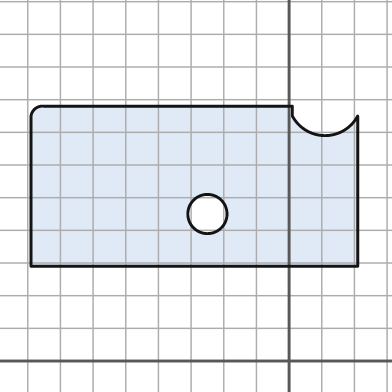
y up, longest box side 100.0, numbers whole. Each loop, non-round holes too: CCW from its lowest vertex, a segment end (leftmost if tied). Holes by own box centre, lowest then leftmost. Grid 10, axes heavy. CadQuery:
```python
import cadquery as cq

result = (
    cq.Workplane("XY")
    .moveTo(-79.0, 29.0)
    .lineTo(21.0, 29.0)
    .lineTo(21.0, 75.0)
    .threePointArc((11.0, 69.0), (1.0, 75.0))
    .lineTo(1.0, 78.0)
    .lineTo(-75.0, 78.0)
    .threePointArc((-78.0, 77.0), (-79.0, 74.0))
    .close()
    .moveTo(-25.0, 45.0)
    .circle(6.0)
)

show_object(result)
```